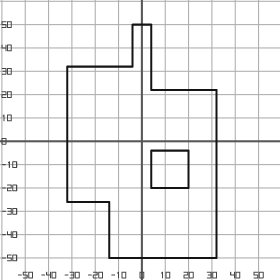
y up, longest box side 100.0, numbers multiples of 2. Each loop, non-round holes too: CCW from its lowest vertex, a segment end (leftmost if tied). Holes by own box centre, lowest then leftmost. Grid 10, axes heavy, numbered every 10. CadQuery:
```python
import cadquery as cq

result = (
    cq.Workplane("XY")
    .moveTo(-14.0, -50.0)
    .lineTo(32.0, -50.0)
    .lineTo(32.0, 22.0)
    .lineTo(4.0, 22.0)
    .lineTo(4.0, 50.0)
    .lineTo(-4.0, 50.0)
    .lineTo(-4.0, 32.0)
    .lineTo(-32.0, 32.0)
    .lineTo(-32.0, -26.0)
    .lineTo(-14.0, -26.0)
    .close()
    .moveTo(4.0, -20.0)
    .lineTo(20.0, -20.0)
    .lineTo(20.0, -4.0)
    .lineTo(4.0, -4.0)
    .close()
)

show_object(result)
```